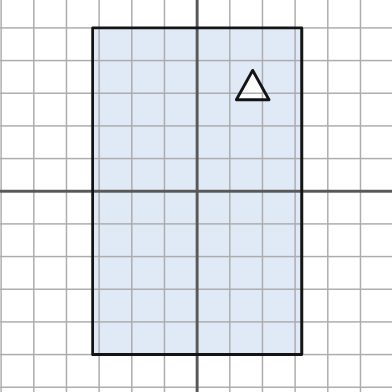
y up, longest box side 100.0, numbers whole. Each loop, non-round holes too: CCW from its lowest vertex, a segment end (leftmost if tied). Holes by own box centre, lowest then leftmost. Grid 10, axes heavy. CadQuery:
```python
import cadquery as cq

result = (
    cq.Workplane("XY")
    .moveTo(-32.0, -50.0)
    .lineTo(32.0, -50.0)
    .lineTo(32.0, 50.0)
    .lineTo(-32.0, 50.0)
    .close()
    .moveTo(12.0, 28.0)
    .lineTo(22.0, 28.0)
    .lineTo(17.0, 37.0)
    .close()
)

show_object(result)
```